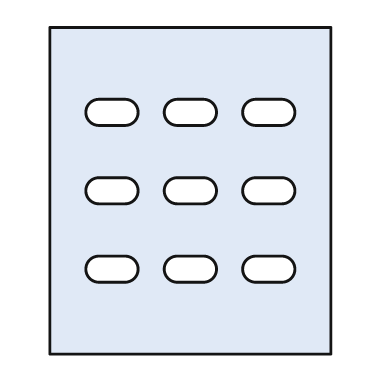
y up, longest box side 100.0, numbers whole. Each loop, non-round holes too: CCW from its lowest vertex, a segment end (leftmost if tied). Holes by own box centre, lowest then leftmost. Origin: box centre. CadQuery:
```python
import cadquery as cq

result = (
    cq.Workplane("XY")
    .moveTo(-43.0, -50.0)
    .lineTo(43.0, -50.0)
    .lineTo(43.0, 50.0)
    .lineTo(-43.0, 50.0)
    .close()
    .moveTo(-28.0, -28.0)
    .lineTo(-20.0, -28.0)
    .threePointArc((-16.0, -24.0), (-20.0, -20.0))
    .lineTo(-28.0, -20.0)
    .threePointArc((-32.0, -24.0), (-28.0, -28.0))
    .close()
    .moveTo(-4.0, -28.0)
    .lineTo(4.0, -28.0)
    .threePointArc((8.0, -24.0), (4.0, -20.0))
    .lineTo(-4.0, -20.0)
    .threePointArc((-8.0, -24.0), (-4.0, -28.0))
    .close()
    .moveTo(20.0, -28.0)
    .lineTo(28.0, -28.0)
    .threePointArc((32.0, -24.0), (28.0, -20.0))
    .lineTo(20.0, -20.0)
    .threePointArc((16.0, -24.0), (20.0, -28.0))
    .close()
    .moveTo(-28.0, -4.0)
    .lineTo(-20.0, -4.0)
    .threePointArc((-16.0, 0.0), (-20.0, 4.0))
    .lineTo(-28.0, 4.0)
    .threePointArc((-32.0, 0.0), (-28.0, -4.0))
    .close()
    .moveTo(-4.0, -4.0)
    .lineTo(4.0, -4.0)
    .threePointArc((8.0, 0.0), (4.0, 4.0))
    .lineTo(-4.0, 4.0)
    .threePointArc((-8.0, 0.0), (-4.0, -4.0))
    .close()
    .moveTo(20.0, -4.0)
    .lineTo(28.0, -4.0)
    .threePointArc((32.0, 0.0), (28.0, 4.0))
    .lineTo(20.0, 4.0)
    .threePointArc((16.0, 0.0), (20.0, -4.0))
    .close()
    .moveTo(-28.0, 20.0)
    .lineTo(-20.0, 20.0)
    .threePointArc((-16.0, 24.0), (-20.0, 28.0))
    .lineTo(-28.0, 28.0)
    .threePointArc((-32.0, 24.0), (-28.0, 20.0))
    .close()
    .moveTo(-4.0, 20.0)
    .lineTo(4.0, 20.0)
    .threePointArc((8.0, 24.0), (4.0, 28.0))
    .lineTo(-4.0, 28.0)
    .threePointArc((-8.0, 24.0), (-4.0, 20.0))
    .close()
    .moveTo(20.0, 20.0)
    .lineTo(28.0, 20.0)
    .threePointArc((32.0, 24.0), (28.0, 28.0))
    .lineTo(20.0, 28.0)
    .threePointArc((16.0, 24.0), (20.0, 20.0))
    .close()
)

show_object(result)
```